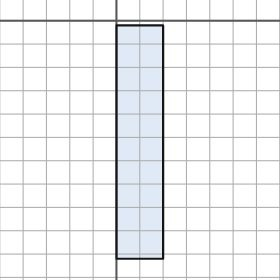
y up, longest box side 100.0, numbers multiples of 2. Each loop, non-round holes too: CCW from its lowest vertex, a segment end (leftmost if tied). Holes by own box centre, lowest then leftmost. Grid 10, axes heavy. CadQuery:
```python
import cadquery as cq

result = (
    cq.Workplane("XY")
    .moveTo(0.0, -102.0)
    .lineTo(20.0, -102.0)
    .lineTo(20.0, -2.0)
    .lineTo(0.0, -2.0)
    .close()
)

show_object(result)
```